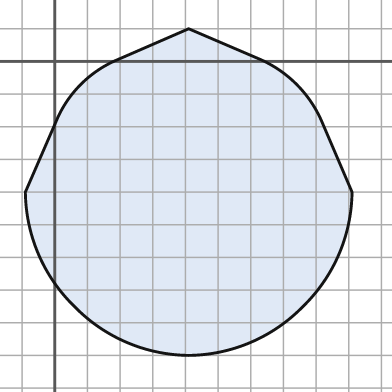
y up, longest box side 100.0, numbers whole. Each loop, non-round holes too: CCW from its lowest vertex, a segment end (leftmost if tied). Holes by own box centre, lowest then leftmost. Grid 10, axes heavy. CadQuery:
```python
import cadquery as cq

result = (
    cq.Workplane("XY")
    .moveTo(41.0, -90.0)
    .threePointArc((60.0, -86.0), (76.0, -75.0))
    .threePointArc((87.0, -59.0), (91.0, -40.0))
    .lineTo(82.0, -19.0)
    .threePointArc((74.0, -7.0), (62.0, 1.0))
    .lineTo(41.0, 10.0)
    .lineTo(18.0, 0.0)
    .threePointArc((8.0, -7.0), (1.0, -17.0))
    .lineTo(-9.0, -40.0)
    .threePointArc((-5.0, -59.0), (6.0, -75.0))
    .threePointArc((22.0, -86.0), (41.0, -90.0))
    .close()
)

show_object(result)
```